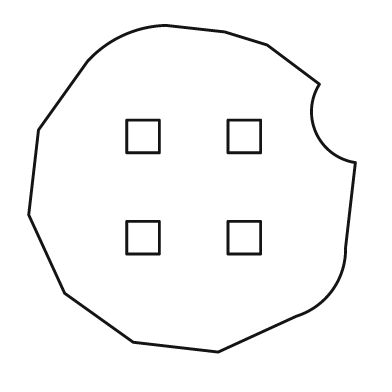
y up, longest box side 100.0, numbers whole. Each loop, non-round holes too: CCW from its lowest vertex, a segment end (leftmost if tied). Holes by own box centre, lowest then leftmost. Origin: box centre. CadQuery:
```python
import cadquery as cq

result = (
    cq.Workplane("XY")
    .moveTo(8.0, -50.0)
    .lineTo(32.0, -39.0)
    .threePointArc((43.0, -31.0), (47.0, -18.0))
    .lineTo(50.0, 8.0)
    .threePointArc((38.0, 17.0), (39.0, 32.0))
    .lineTo(23.0, 44.0)
    .lineTo(10.0, 48.0)
    .lineTo(-8.0, 50.0)
    .threePointArc((-21.0, 47.0), (-32.0, 39.0))
    .lineTo(-47.0, 18.0)
    .lineTo(-50.0, -8.0)
    .lineTo(-39.0, -32.0)
    .lineTo(-18.0, -47.0)
    .close()
    .moveTo(-20.0, -20.0)
    .lineTo(-10.0, -20.0)
    .lineTo(-10.0, -10.0)
    .lineTo(-20.0, -10.0)
    .close()
    .moveTo(11.0, -20.0)
    .lineTo(21.0, -20.0)
    .lineTo(21.0, -10.0)
    .lineTo(11.0, -10.0)
    .close()
    .moveTo(-20.0, 11.0)
    .lineTo(-10.0, 11.0)
    .lineTo(-10.0, 21.0)
    .lineTo(-20.0, 21.0)
    .close()
    .moveTo(11.0, 11.0)
    .lineTo(21.0, 11.0)
    .lineTo(21.0, 21.0)
    .lineTo(11.0, 21.0)
    .close()
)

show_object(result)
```